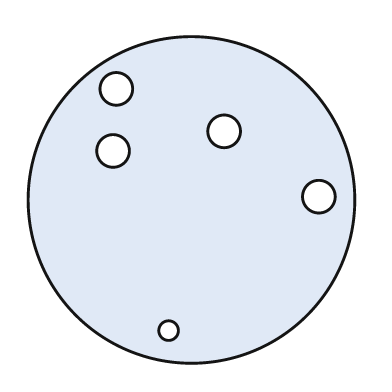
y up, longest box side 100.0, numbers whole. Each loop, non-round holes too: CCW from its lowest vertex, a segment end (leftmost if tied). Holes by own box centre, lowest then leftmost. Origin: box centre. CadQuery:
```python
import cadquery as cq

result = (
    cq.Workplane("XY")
    .moveTo(0.0, 0.0)
    .circle(50.0)
    .moveTo(-7.0, -40.0)
    .circle(3.0)
    .moveTo(39.0, 1.0)
    .circle(5.0)
    .moveTo(-24.0, 15.0)
    .circle(5.0)
    .moveTo(10.0, 21.0)
    .circle(5.0)
    .moveTo(-23.0, 34.0)
    .circle(5.0)
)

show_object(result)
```